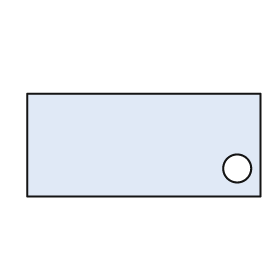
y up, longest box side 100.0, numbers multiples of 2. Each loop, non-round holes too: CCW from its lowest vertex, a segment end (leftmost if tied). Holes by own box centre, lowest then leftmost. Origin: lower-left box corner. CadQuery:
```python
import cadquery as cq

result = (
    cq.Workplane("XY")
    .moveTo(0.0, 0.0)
    .lineTo(100.0, 0.0)
    .lineTo(100.0, 44.0)
    .lineTo(0.0, 44.0)
    .close()
    .moveTo(90.0, 12.0)
    .circle(6.0)
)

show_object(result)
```